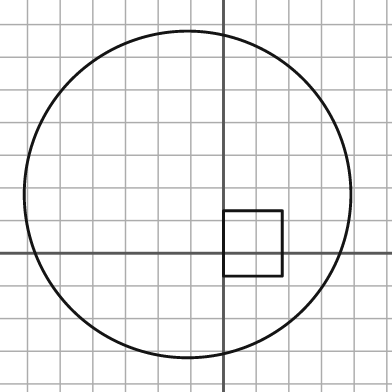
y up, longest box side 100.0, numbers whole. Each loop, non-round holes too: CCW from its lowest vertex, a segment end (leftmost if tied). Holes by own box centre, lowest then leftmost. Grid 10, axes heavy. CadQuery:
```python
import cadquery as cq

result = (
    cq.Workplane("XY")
    .moveTo(-11.0, 18.0)
    .circle(50.0)
    .moveTo(0.0, -7.0)
    .lineTo(18.0, -7.0)
    .lineTo(18.0, 13.0)
    .lineTo(0.0, 13.0)
    .close()
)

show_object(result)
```